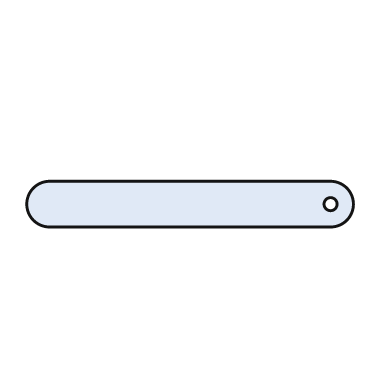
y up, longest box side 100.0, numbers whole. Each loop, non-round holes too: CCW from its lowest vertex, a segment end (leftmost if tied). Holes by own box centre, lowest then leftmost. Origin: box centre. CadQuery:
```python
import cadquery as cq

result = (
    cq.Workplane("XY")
    .moveTo(-43.0, -7.0)
    .lineTo(43.0, -7.0)
    .threePointArc((50.0, 0.0), (43.0, 7.0))
    .lineTo(-43.0, 7.0)
    .threePointArc((-50.0, 0.0), (-43.0, -7.0))
    .close()
    .moveTo(43.0, 0.0)
    .circle(2.0)
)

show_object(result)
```